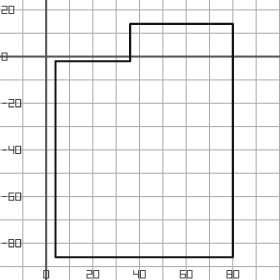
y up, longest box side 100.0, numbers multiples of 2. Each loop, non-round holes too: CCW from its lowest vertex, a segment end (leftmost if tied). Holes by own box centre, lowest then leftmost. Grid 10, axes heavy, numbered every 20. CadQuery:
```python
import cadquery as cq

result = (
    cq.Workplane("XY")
    .moveTo(4.0, -86.0)
    .lineTo(80.0, -86.0)
    .lineTo(80.0, 14.0)
    .lineTo(36.0, 14.0)
    .lineTo(36.0, -2.0)
    .lineTo(4.0, -2.0)
    .close()
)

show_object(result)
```